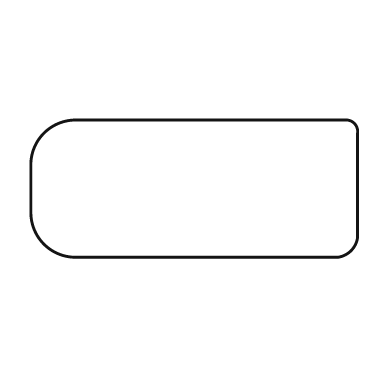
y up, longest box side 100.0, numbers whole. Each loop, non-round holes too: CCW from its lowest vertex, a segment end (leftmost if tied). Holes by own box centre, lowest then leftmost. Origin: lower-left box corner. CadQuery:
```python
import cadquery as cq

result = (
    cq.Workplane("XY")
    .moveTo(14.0, 0.0)
    .lineTo(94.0, 0.0)
    .threePointArc((98.0, 2.0), (100.0, 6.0))
    .lineTo(100.0, 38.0)
    .threePointArc((99.0, 41.0), (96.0, 42.0))
    .lineTo(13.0, 42.0)
    .threePointArc((4.0, 38.0), (0.0, 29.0))
    .lineTo(0.0, 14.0)
    .threePointArc((4.0, 4.0), (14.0, 0.0))
    .close()
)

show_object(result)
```